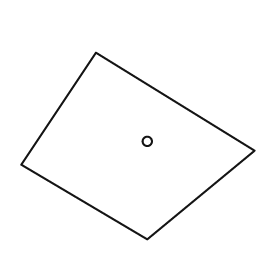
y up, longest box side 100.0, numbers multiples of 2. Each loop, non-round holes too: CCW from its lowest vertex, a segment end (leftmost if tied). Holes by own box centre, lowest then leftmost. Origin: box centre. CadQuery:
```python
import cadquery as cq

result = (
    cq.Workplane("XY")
    .moveTo(4.0, -40.0)
    .lineTo(50.0, -2.0)
    .lineTo(-18.0, 40.0)
    .lineTo(-50.0, -8.0)
    .close()
    .moveTo(4.0, 2.0)
    .circle(2.0)
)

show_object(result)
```